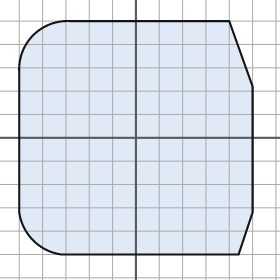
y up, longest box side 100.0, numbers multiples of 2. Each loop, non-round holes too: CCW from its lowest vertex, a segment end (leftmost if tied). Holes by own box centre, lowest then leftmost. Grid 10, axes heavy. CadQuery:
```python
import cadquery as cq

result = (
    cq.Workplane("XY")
    .moveTo(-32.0, -50.0)
    .lineTo(44.0, -50.0)
    .lineTo(50.0, -32.0)
    .lineTo(50.0, 22.0)
    .lineTo(40.0, 50.0)
    .lineTo(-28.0, 50.0)
    .threePointArc((-44.0, 44.0), (-50.0, 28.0))
    .lineTo(-50.0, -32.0)
    .threePointArc((-44.0, -44.0), (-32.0, -50.0))
    .close()
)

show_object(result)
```